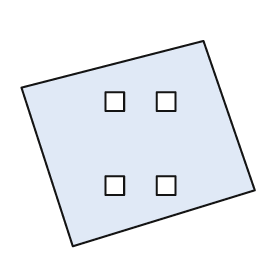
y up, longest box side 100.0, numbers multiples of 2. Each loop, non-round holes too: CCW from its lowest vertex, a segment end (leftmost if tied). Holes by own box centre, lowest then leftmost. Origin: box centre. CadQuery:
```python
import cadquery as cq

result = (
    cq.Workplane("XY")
    .moveTo(-28.0, -44.0)
    .lineTo(50.0, -20.0)
    .lineTo(28.0, 44.0)
    .lineTo(-50.0, 24.0)
    .close()
    .moveTo(-14.0, -22.0)
    .lineTo(-6.0, -22.0)
    .lineTo(-6.0, -14.0)
    .lineTo(-14.0, -14.0)
    .close()
    .moveTo(8.0, -22.0)
    .lineTo(16.0, -22.0)
    .lineTo(16.0, -14.0)
    .lineTo(8.0, -14.0)
    .close()
    .moveTo(-14.0, 14.0)
    .lineTo(-6.0, 14.0)
    .lineTo(-6.0, 22.0)
    .lineTo(-14.0, 22.0)
    .close()
    .moveTo(8.0, 14.0)
    .lineTo(16.0, 14.0)
    .lineTo(16.0, 22.0)
    .lineTo(8.0, 22.0)
    .close()
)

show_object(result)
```